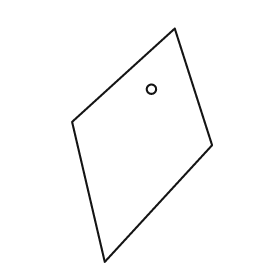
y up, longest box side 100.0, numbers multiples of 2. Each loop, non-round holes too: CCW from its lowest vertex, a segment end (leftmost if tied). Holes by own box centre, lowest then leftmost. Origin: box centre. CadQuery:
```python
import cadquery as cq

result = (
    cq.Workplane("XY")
    .moveTo(-16.0, -50.0)
    .lineTo(30.0, 0.0)
    .lineTo(14.0, 50.0)
    .lineTo(-30.0, 10.0)
    .close()
    .moveTo(4.0, 24.0)
    .circle(2.0)
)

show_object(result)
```